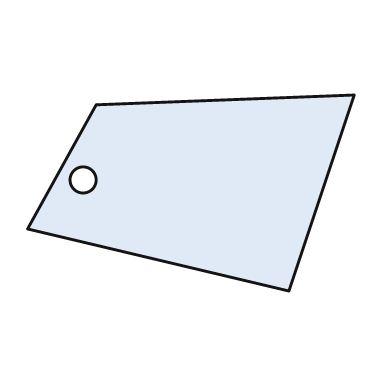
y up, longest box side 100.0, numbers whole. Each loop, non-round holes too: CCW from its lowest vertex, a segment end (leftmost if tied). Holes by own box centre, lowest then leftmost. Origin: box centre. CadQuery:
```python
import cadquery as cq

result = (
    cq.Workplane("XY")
    .moveTo(30.0, -30.0)
    .lineTo(50.0, 30.0)
    .lineTo(-29.0, 27.0)
    .lineTo(-50.0, -11.0)
    .close()
    .moveTo(-33.0, 4.0)
    .circle(4.0)
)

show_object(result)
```